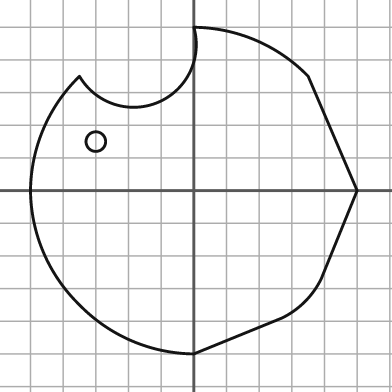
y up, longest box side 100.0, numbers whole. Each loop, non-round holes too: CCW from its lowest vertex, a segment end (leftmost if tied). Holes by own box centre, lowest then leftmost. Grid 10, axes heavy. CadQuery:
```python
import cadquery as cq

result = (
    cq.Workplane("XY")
    .moveTo(0.0, -50.0)
    .lineTo(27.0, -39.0)
    .threePointArc((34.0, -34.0), (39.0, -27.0))
    .lineTo(50.0, 0.0)
    .lineTo(35.0, 35.0)
    .threePointArc((19.0, 46.0), (0.0, 50.0))
    .threePointArc((-11.0, 27.0), (-35.0, 35.0))
    .threePointArc((-46.0, 19.0), (-50.0, 0.0))
    .threePointArc((-46.0, -19.0), (-35.0, -35.0))
    .threePointArc((-19.0, -46.0), (0.0, -50.0))
    .close()
    .moveTo(-30.0, 15.0)
    .circle(3.0)
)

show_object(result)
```